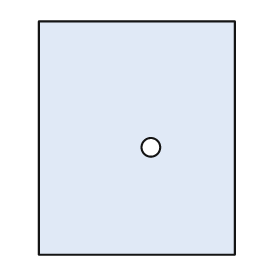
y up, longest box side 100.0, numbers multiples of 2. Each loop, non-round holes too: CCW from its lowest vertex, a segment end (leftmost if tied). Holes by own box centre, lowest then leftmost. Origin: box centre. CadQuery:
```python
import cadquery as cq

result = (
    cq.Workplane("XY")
    .moveTo(-42.0, -50.0)
    .lineTo(42.0, -50.0)
    .lineTo(42.0, 50.0)
    .lineTo(-42.0, 50.0)
    .close()
    .moveTo(6.0, -4.0)
    .circle(4.0)
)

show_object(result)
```